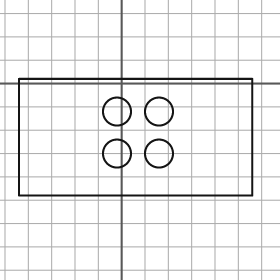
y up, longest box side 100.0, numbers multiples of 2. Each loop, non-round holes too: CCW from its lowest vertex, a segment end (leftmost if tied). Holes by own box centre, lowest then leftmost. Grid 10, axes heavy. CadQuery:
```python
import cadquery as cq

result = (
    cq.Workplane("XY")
    .moveTo(-44.0, -48.0)
    .lineTo(56.0, -48.0)
    .lineTo(56.0, 2.0)
    .lineTo(-44.0, 2.0)
    .close()
    .moveTo(-2.0, -30.0)
    .circle(6.0)
    .moveTo(16.0, -30.0)
    .circle(6.0)
    .moveTo(-2.0, -12.0)
    .circle(6.0)
    .moveTo(16.0, -12.0)
    .circle(6.0)
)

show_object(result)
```